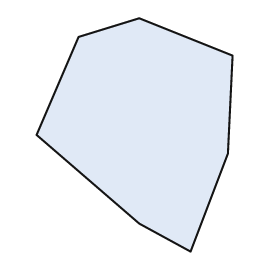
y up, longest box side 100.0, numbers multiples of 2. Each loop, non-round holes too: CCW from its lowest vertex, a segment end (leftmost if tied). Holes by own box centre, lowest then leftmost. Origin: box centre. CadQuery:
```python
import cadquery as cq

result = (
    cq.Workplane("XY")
    .moveTo(24.0, -50.0)
    .lineTo(40.0, -8.0)
    .lineTo(42.0, 34.0)
    .lineTo(2.0, 50.0)
    .lineTo(-24.0, 42.0)
    .lineTo(-42.0, 0.0)
    .lineTo(2.0, -38.0)
    .close()
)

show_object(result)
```